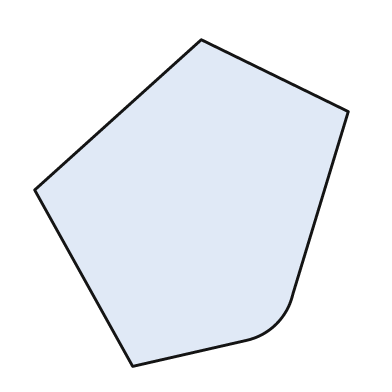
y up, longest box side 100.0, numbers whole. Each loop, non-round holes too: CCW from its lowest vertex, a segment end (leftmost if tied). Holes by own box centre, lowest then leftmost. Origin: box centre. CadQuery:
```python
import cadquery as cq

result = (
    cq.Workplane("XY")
    .moveTo(-18.0, -50.0)
    .lineTo(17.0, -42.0)
    .threePointArc((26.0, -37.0), (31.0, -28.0))
    .lineTo(48.0, 28.0)
    .lineTo(3.0, 50.0)
    .lineTo(-48.0, 4.0)
    .close()
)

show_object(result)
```